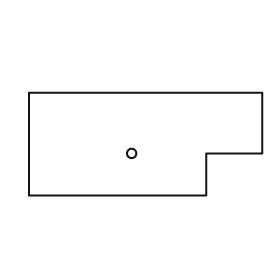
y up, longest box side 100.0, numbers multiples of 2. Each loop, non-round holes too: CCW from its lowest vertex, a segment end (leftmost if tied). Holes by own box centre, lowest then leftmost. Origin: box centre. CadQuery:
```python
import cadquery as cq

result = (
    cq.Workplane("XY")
    .moveTo(-50.0, -22.0)
    .lineTo(26.0, -22.0)
    .lineTo(26.0, -4.0)
    .lineTo(50.0, -4.0)
    .lineTo(50.0, 22.0)
    .lineTo(-50.0, 22.0)
    .close()
    .moveTo(-6.0, -4.0)
    .circle(2.0)
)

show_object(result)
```